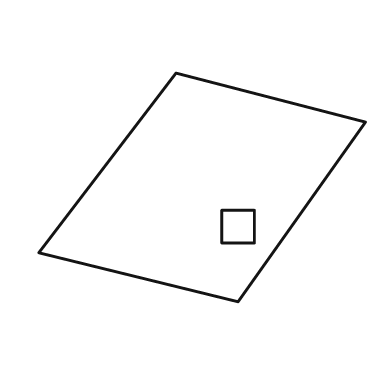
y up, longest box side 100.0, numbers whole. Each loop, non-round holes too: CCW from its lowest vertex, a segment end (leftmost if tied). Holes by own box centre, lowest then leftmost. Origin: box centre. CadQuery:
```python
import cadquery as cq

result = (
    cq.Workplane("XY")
    .moveTo(11.0, -35.0)
    .lineTo(50.0, 20.0)
    .lineTo(-8.0, 35.0)
    .lineTo(-50.0, -20.0)
    .close()
    .moveTo(6.0, -17.0)
    .lineTo(16.0, -17.0)
    .lineTo(16.0, -7.0)
    .lineTo(6.0, -7.0)
    .close()
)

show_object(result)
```